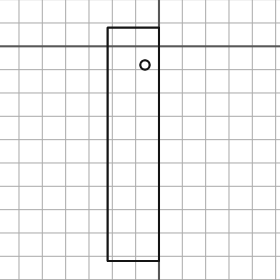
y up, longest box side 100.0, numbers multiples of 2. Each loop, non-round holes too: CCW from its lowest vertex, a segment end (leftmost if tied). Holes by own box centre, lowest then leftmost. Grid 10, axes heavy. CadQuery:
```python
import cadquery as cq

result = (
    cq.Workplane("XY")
    .moveTo(-22.0, -92.0)
    .lineTo(0.0, -92.0)
    .lineTo(0.0, 8.0)
    .lineTo(-22.0, 8.0)
    .close()
    .moveTo(-6.0, -8.0)
    .circle(2.0)
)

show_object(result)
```